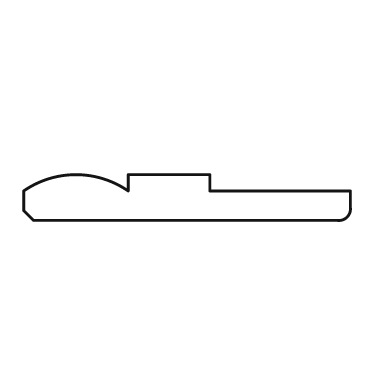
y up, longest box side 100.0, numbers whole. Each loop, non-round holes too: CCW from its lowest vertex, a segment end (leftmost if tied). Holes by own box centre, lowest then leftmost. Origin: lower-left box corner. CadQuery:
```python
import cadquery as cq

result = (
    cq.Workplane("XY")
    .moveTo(3.0, 0.0)
    .lineTo(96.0, 0.0)
    .threePointArc((99.0, 1.0), (100.0, 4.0))
    .lineTo(100.0, 9.0)
    .lineTo(57.0, 9.0)
    .lineTo(57.0, 14.0)
    .lineTo(32.0, 14.0)
    .lineTo(32.0, 9.0)
    .threePointArc((16.0, 14.0), (0.0, 9.0))
    .lineTo(0.0, 3.0)
    .close()
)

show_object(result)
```